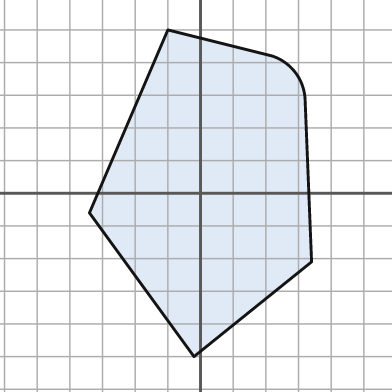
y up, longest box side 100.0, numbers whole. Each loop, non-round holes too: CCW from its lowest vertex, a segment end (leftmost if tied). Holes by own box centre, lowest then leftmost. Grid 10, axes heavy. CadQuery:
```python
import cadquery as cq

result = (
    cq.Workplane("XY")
    .moveTo(-2.0, -50.0)
    .lineTo(34.0, -21.0)
    .lineTo(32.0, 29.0)
    .threePointArc((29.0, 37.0), (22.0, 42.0))
    .lineTo(-10.0, 50.0)
    .lineTo(-34.0, -6.0)
    .close()
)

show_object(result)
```